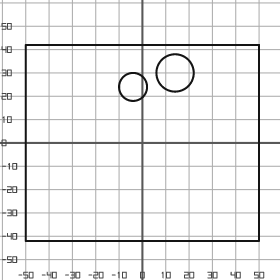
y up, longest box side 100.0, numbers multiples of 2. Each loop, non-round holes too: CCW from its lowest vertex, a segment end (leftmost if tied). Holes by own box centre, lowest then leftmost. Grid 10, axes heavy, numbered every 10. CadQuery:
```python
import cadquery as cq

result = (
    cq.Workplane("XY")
    .moveTo(-50.0, -42.0)
    .lineTo(50.0, -42.0)
    .lineTo(50.0, 42.0)
    .lineTo(-50.0, 42.0)
    .close()
    .moveTo(-4.0, 24.0)
    .circle(6.0)
    .moveTo(14.0, 30.0)
    .circle(8.0)
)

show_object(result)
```